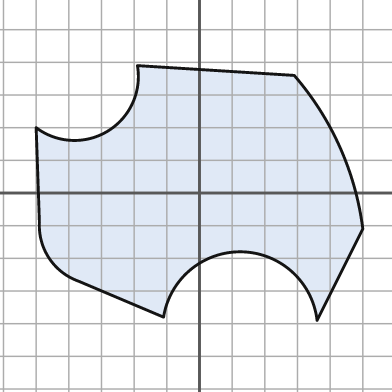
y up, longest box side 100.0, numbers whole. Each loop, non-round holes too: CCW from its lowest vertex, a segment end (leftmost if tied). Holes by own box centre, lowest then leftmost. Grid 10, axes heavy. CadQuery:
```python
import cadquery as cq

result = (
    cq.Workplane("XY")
    .moveTo(36.0, -39.0)
    .lineTo(50.0, -11.0)
    .threePointArc((43.0, 14.0), (29.0, 36.0))
    .lineTo(-19.0, 39.0)
    .threePointArc((-28.0, 19.0), (-50.0, 20.0))
    .lineTo(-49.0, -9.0)
    .threePointArc((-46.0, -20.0), (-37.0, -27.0))
    .lineTo(-11.0, -38.0)
    .threePointArc((13.0, -18.0), (36.0, -39.0))
    .close()
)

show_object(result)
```